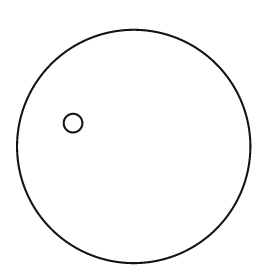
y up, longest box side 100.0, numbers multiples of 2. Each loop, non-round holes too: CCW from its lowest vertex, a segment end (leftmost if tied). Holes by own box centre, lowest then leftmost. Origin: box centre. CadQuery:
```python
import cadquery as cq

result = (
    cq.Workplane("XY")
    .moveTo(0.0, 0.0)
    .circle(50.0)
    .moveTo(-26.0, 10.0)
    .circle(4.0)
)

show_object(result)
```